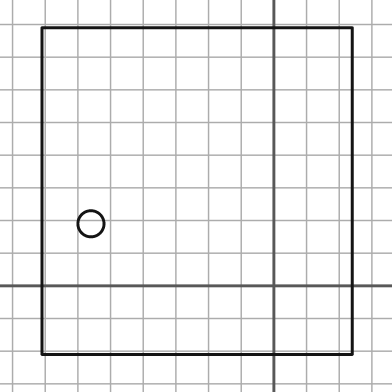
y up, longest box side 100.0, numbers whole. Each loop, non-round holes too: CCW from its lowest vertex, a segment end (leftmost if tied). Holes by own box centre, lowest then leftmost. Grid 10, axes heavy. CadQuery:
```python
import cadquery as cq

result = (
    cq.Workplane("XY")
    .moveTo(-71.0, -21.0)
    .lineTo(24.0, -21.0)
    .lineTo(24.0, 79.0)
    .lineTo(-71.0, 79.0)
    .close()
    .moveTo(-56.0, 19.0)
    .circle(4.0)
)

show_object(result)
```